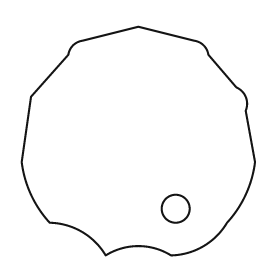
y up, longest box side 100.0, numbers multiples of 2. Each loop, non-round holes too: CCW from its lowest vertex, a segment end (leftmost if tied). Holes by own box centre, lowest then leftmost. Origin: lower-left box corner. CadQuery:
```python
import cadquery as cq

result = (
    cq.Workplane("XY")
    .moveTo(36.0, 0.0)
    .threePointArc((50.0, 4.0), (64.0, 0.0))
    .threePointArc((78.0, 4.0), (88.0, 14.0))
    .threePointArc((96.0, 26.0), (100.0, 40.0))
    .lineTo(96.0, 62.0)
    .threePointArc((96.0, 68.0), (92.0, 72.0))
    .lineTo(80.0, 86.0)
    .threePointArc((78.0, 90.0), (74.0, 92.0))
    .lineTo(50.0, 98.0)
    .lineTo(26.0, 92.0)
    .threePointArc((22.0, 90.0), (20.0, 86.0))
    .lineTo(4.0, 68.0)
    .lineTo(0.0, 40.0)
    .threePointArc((4.0, 26.0), (12.0, 14.0))
    .threePointArc((26.0, 10.0), (36.0, 0.0))
    .close()
    .moveTo(66.0, 20.0)
    .circle(6.0)
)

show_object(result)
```